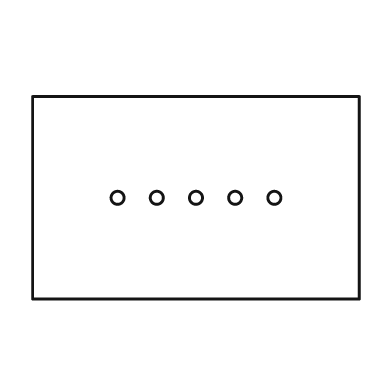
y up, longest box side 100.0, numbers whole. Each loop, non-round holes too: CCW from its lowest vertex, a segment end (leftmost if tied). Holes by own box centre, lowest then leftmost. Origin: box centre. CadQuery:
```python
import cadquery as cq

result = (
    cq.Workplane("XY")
    .moveTo(-50.0, -31.0)
    .lineTo(50.0, -31.0)
    .lineTo(50.0, 31.0)
    .lineTo(-50.0, 31.0)
    .close()
    .moveTo(-24.0, 0.0)
    .circle(2.0)
    .moveTo(-12.0, 0.0)
    .circle(2.0)
    .moveTo(0.0, 0.0)
    .circle(2.0)
    .moveTo(12.0, 0.0)
    .circle(2.0)
    .moveTo(24.0, 0.0)
    .circle(2.0)
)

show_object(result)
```